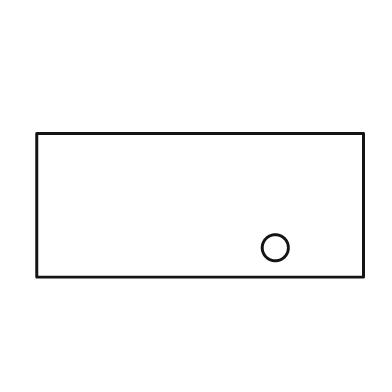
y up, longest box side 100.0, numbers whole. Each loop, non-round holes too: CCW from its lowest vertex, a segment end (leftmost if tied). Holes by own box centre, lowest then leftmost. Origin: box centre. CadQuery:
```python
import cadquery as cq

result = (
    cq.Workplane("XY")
    .moveTo(-50.0, -22.0)
    .lineTo(50.0, -22.0)
    .lineTo(50.0, 22.0)
    .lineTo(-50.0, 22.0)
    .close()
    .moveTo(23.0, -13.0)
    .circle(4.0)
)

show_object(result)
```